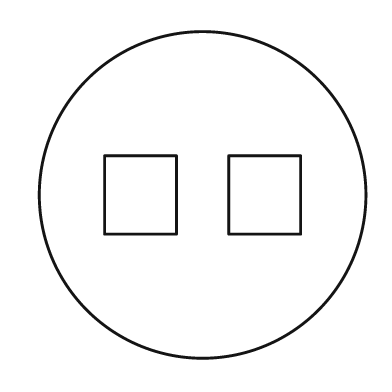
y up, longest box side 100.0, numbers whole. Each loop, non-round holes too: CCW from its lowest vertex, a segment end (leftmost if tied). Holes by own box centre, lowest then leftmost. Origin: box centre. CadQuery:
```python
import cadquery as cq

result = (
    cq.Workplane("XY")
    .moveTo(0.0, 0.0)
    .circle(50.0)
    .moveTo(-30.0, -12.0)
    .lineTo(-8.0, -12.0)
    .lineTo(-8.0, 12.0)
    .lineTo(-30.0, 12.0)
    .close()
    .moveTo(8.0, -12.0)
    .lineTo(30.0, -12.0)
    .lineTo(30.0, 12.0)
    .lineTo(8.0, 12.0)
    .close()
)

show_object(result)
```